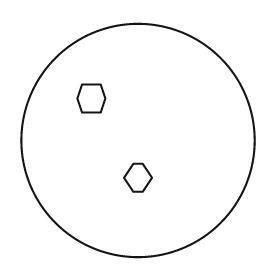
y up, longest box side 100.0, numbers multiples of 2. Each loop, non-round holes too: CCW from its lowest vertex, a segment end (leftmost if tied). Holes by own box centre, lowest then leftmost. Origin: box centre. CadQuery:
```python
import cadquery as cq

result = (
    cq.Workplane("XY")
    .moveTo(0.0, 0.0)
    .circle(50.0)
    .moveTo(-2.0, -22.0)
    .lineTo(2.0, -22.0)
    .lineTo(6.0, -16.0)
    .lineTo(2.0, -10.0)
    .lineTo(-2.0, -10.0)
    .lineTo(-6.0, -16.0)
    .close()
    .moveTo(-24.0, 12.0)
    .lineTo(-16.0, 12.0)
    .lineTo(-14.0, 18.0)
    .lineTo(-16.0, 24.0)
    .lineTo(-24.0, 24.0)
    .lineTo(-26.0, 18.0)
    .close()
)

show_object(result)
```